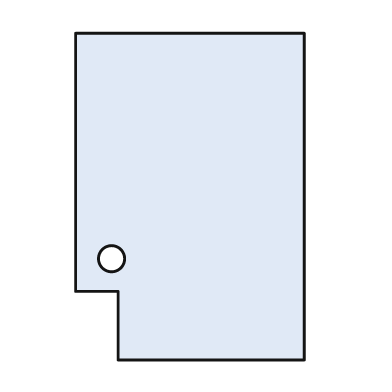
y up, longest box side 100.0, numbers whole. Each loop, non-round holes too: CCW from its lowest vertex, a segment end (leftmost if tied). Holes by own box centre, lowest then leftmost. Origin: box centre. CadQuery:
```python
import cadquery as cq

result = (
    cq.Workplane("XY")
    .moveTo(-22.0, -50.0)
    .lineTo(35.0, -50.0)
    .lineTo(35.0, 50.0)
    .lineTo(-35.0, 50.0)
    .lineTo(-35.0, -29.0)
    .lineTo(-22.0, -29.0)
    .close()
    .moveTo(-24.0, -19.0)
    .circle(4.0)
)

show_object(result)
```